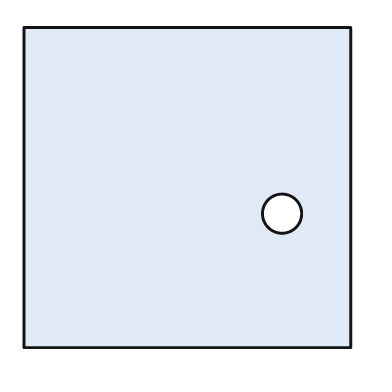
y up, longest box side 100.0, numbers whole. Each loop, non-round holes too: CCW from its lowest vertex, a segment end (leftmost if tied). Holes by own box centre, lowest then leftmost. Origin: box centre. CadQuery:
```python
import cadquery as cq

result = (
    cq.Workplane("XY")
    .moveTo(-50.0, -49.0)
    .lineTo(50.0, -49.0)
    .lineTo(50.0, 49.0)
    .lineTo(-50.0, 49.0)
    .close()
    .moveTo(29.0, -8.0)
    .circle(6.0)
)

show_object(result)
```